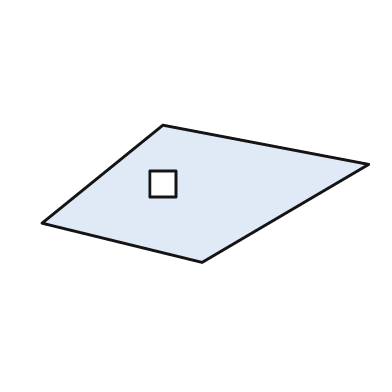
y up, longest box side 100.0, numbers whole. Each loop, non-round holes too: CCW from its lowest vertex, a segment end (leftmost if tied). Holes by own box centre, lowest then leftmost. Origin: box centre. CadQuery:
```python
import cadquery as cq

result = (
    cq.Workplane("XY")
    .moveTo(-1.0, -21.0)
    .lineTo(50.0, 9.0)
    .lineTo(-13.0, 21.0)
    .lineTo(-50.0, -9.0)
    .close()
    .moveTo(-17.0, -1.0)
    .lineTo(-9.0, -1.0)
    .lineTo(-9.0, 7.0)
    .lineTo(-17.0, 7.0)
    .close()
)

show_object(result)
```